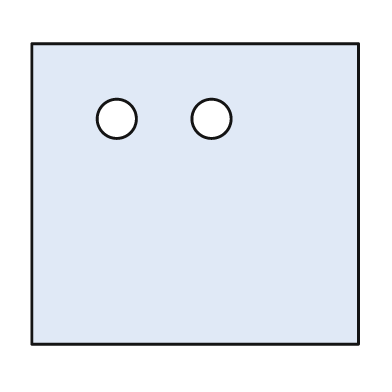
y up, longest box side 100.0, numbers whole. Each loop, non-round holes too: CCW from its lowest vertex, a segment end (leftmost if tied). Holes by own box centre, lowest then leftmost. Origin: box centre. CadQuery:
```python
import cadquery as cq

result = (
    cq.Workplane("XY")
    .moveTo(-50.0, -46.0)
    .lineTo(50.0, -46.0)
    .lineTo(50.0, 46.0)
    .lineTo(-50.0, 46.0)
    .close()
    .moveTo(-24.0, 23.0)
    .circle(6.0)
    .moveTo(5.0, 23.0)
    .circle(6.0)
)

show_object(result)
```